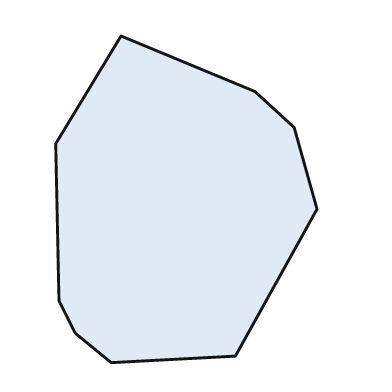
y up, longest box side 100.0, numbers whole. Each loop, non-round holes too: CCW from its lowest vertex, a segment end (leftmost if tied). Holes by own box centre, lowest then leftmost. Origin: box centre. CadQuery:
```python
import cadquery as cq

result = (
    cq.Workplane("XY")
    .moveTo(-23.0, -50.0)
    .lineTo(15.0, -48.0)
    .lineTo(40.0, -3.0)
    .lineTo(33.0, 22.0)
    .lineTo(21.0, 33.0)
    .lineTo(-20.0, 50.0)
    .lineTo(-40.0, 17.0)
    .lineTo(-39.0, -31.0)
    .lineTo(-34.0, -41.0)
    .close()
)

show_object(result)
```